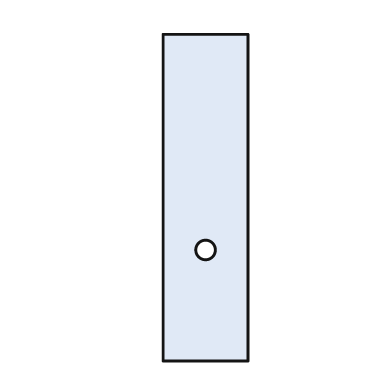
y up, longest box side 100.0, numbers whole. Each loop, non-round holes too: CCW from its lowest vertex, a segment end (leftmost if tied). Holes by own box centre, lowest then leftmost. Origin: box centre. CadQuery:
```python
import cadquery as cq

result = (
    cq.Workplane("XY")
    .moveTo(-13.0, -50.0)
    .lineTo(13.0, -50.0)
    .lineTo(13.0, 50.0)
    .lineTo(-13.0, 50.0)
    .close()
    .moveTo(0.0, -16.0)
    .circle(3.0)
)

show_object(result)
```